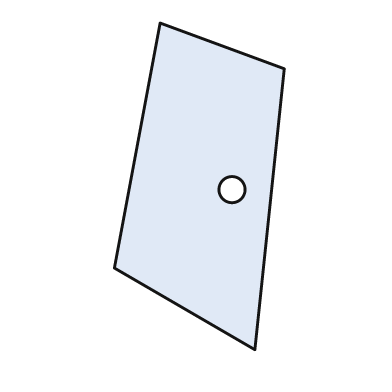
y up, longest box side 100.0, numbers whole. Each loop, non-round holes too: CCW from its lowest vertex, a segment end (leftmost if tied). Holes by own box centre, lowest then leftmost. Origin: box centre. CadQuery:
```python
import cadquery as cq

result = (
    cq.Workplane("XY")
    .moveTo(17.0, -50.0)
    .lineTo(26.0, 36.0)
    .lineTo(-12.0, 50.0)
    .lineTo(-26.0, -25.0)
    .close()
    .moveTo(10.0, -1.0)
    .circle(4.0)
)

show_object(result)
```